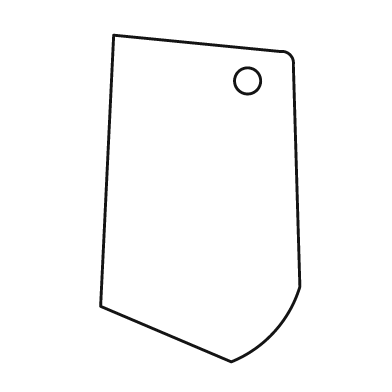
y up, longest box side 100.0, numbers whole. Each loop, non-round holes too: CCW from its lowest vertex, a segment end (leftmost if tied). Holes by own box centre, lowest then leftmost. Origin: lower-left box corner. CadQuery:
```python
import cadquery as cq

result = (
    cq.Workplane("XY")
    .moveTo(40.0, 0.0)
    .threePointArc((53.0, 9.0), (61.0, 23.0))
    .lineTo(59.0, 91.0)
    .threePointArc((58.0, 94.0), (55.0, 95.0))
    .lineTo(4.0, 100.0)
    .lineTo(0.0, 17.0)
    .close()
    .moveTo(45.0, 86.0)
    .circle(4.0)
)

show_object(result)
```